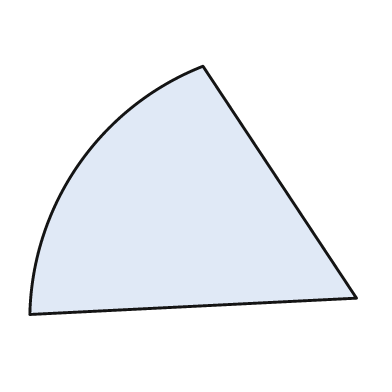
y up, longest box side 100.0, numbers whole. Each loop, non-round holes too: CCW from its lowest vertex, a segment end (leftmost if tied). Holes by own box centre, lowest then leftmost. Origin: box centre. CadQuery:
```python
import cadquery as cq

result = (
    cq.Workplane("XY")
    .moveTo(-50.0, -38.0)
    .lineTo(50.0, -33.0)
    .lineTo(3.0, 38.0)
    .threePointArc((-35.0, 8.0), (-50.0, -38.0))
    .close()
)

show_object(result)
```